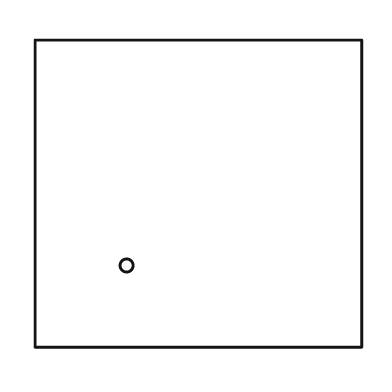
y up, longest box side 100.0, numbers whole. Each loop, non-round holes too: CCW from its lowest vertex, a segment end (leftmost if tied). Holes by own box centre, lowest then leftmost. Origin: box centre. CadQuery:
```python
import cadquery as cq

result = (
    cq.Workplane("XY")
    .moveTo(-50.0, -47.0)
    .lineTo(50.0, -47.0)
    .lineTo(50.0, 47.0)
    .lineTo(-50.0, 47.0)
    .close()
    .moveTo(-22.0, -22.0)
    .circle(2.0)
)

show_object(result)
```